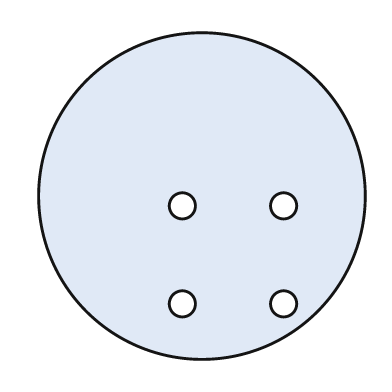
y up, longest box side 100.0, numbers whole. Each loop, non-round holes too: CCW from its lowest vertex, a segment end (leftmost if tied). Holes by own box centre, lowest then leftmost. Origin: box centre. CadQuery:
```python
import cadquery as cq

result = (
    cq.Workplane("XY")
    .moveTo(0.0, 0.0)
    .circle(50.0)
    .moveTo(-6.0, -33.0)
    .circle(4.0)
    .moveTo(25.0, -33.0)
    .circle(4.0)
    .moveTo(-6.0, -3.0)
    .circle(4.0)
    .moveTo(25.0, -3.0)
    .circle(4.0)
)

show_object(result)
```